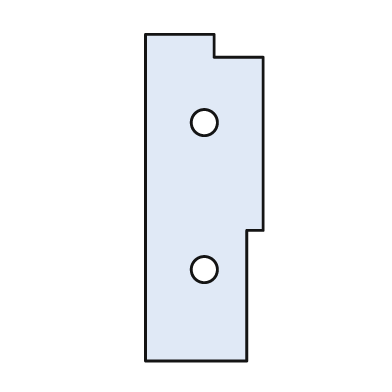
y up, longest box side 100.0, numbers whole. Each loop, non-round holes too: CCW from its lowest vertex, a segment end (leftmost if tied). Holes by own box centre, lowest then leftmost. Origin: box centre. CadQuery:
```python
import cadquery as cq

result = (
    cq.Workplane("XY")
    .moveTo(-18.0, -50.0)
    .lineTo(13.0, -50.0)
    .lineTo(13.0, -10.0)
    .lineTo(18.0, -10.0)
    .lineTo(18.0, 43.0)
    .lineTo(3.0, 43.0)
    .lineTo(3.0, 50.0)
    .lineTo(-18.0, 50.0)
    .close()
    .moveTo(0.0, -22.0)
    .circle(4.0)
    .moveTo(0.0, 23.0)
    .circle(4.0)
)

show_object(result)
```